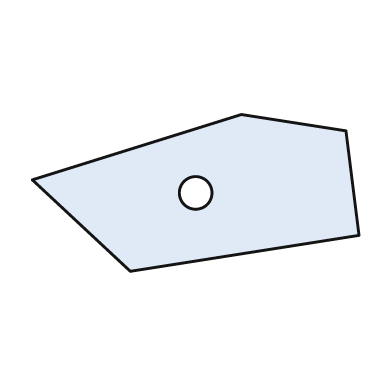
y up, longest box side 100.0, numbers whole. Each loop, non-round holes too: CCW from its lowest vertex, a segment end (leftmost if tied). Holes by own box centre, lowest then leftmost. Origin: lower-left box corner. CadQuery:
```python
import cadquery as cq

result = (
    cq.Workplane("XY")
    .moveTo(30.0, 0.0)
    .lineTo(100.0, 11.0)
    .lineTo(96.0, 43.0)
    .lineTo(64.0, 48.0)
    .lineTo(0.0, 28.0)
    .close()
    .moveTo(50.0, 24.0)
    .circle(5.0)
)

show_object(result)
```